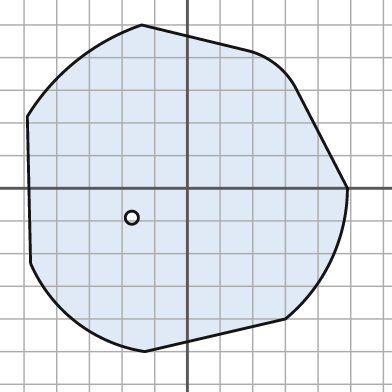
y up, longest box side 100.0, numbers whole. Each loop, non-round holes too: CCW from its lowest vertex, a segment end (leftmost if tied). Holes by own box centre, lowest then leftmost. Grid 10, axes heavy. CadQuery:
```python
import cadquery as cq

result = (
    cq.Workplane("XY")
    .moveTo(-13.0, -50.0)
    .lineTo(30.0, -40.0)
    .threePointArc((44.0, -22.0), (49.0, 0.0))
    .lineTo(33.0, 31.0)
    .threePointArc((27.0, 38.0), (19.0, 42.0))
    .lineTo(-14.0, 50.0)
    .threePointArc((-34.0, 39.0), (-49.0, 22.0))
    .lineTo(-48.0, -23.0)
    .threePointArc((-34.0, -41.0), (-13.0, -50.0))
    .close()
    .moveTo(-17.0, -9.0)
    .circle(2.0)
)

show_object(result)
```